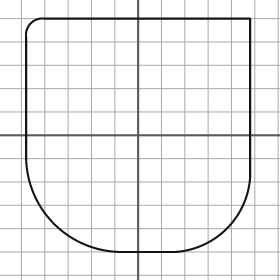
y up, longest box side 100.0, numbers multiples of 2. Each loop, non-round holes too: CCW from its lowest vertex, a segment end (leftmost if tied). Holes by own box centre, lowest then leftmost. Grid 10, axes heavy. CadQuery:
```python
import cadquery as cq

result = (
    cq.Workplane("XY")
    .moveTo(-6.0, -50.0)
    .lineTo(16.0, -50.0)
    .threePointArc((38.0, -40.0), (48.0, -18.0))
    .lineTo(48.0, 50.0)
    .lineTo(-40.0, 50.0)
    .threePointArc((-46.0, 48.0), (-48.0, 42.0))
    .lineTo(-48.0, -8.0)
    .threePointArc((-36.0, -38.0), (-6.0, -50.0))
    .close()
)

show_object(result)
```